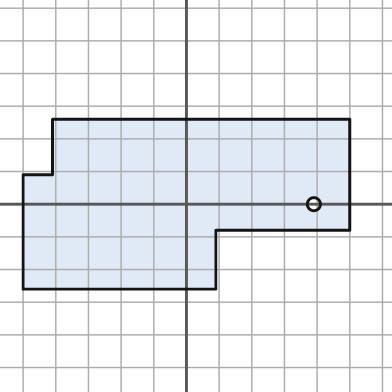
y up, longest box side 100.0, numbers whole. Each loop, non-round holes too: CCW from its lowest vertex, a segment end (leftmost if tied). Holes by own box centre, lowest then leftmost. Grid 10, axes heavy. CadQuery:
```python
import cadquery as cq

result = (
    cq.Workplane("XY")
    .moveTo(-50.0, -26.0)
    .lineTo(9.0, -26.0)
    .lineTo(9.0, -8.0)
    .lineTo(50.0, -8.0)
    .lineTo(50.0, 26.0)
    .lineTo(-41.0, 26.0)
    .lineTo(-41.0, 9.0)
    .lineTo(-50.0, 9.0)
    .close()
    .moveTo(39.0, 0.0)
    .circle(2.0)
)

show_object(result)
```